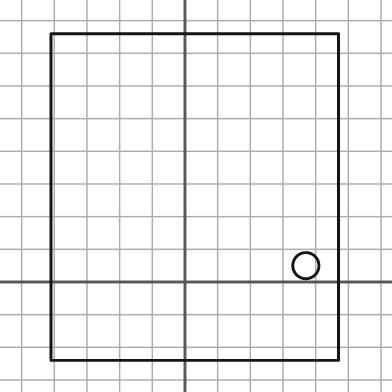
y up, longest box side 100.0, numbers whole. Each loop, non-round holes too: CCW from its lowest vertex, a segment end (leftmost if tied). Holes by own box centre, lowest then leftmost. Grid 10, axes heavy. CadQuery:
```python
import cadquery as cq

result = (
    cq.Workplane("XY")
    .moveTo(-41.0, -24.0)
    .lineTo(47.0, -24.0)
    .lineTo(47.0, 76.0)
    .lineTo(-41.0, 76.0)
    .close()
    .moveTo(37.0, 5.0)
    .circle(4.0)
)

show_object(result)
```